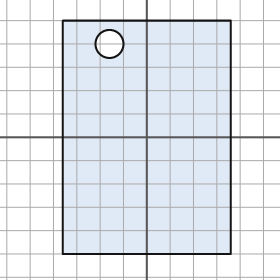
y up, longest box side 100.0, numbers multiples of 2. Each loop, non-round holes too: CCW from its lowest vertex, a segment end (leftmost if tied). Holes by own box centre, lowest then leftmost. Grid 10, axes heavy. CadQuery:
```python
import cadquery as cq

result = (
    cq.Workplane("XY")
    .moveTo(-36.0, -50.0)
    .lineTo(36.0, -50.0)
    .lineTo(36.0, 50.0)
    .lineTo(-36.0, 50.0)
    .close()
    .moveTo(-16.0, 40.0)
    .circle(6.0)
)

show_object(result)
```